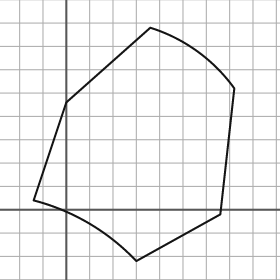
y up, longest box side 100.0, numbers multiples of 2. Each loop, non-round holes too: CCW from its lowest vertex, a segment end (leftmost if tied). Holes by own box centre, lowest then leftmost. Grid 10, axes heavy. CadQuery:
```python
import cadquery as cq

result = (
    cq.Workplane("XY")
    .moveTo(30.0, -22.0)
    .lineTo(66.0, -2.0)
    .lineTo(72.0, 52.0)
    .threePointArc((56.0, 68.0), (36.0, 78.0))
    .lineTo(0.0, 46.0)
    .lineTo(-14.0, 4.0)
    .threePointArc((10.0, -6.0), (30.0, -22.0))
    .close()
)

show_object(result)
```